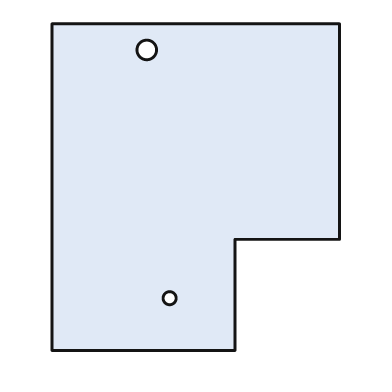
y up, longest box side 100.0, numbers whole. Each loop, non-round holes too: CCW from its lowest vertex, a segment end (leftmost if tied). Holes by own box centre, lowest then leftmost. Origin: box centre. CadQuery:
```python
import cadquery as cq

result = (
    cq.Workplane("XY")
    .moveTo(-44.0, -50.0)
    .lineTo(12.0, -50.0)
    .lineTo(12.0, -16.0)
    .lineTo(44.0, -16.0)
    .lineTo(44.0, 50.0)
    .lineTo(-44.0, 50.0)
    .close()
    .moveTo(-8.0, -34.0)
    .circle(2.0)
    .moveTo(-15.0, 42.0)
    .circle(3.0)
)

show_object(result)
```